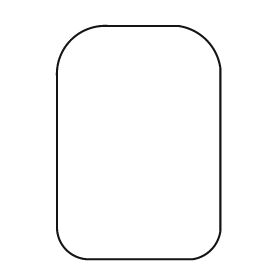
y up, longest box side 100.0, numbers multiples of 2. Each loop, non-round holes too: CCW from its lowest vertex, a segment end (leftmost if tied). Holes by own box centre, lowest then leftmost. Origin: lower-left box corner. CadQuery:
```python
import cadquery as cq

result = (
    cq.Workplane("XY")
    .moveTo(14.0, 0.0)
    .lineTo(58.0, 0.0)
    .threePointArc((66.0, 4.0), (70.0, 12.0))
    .lineTo(70.0, 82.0)
    .threePointArc((64.0, 94.0), (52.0, 100.0))
    .lineTo(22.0, 100.0)
    .threePointArc((6.0, 94.0), (0.0, 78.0))
    .lineTo(0.0, 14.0)
    .threePointArc((4.0, 4.0), (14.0, 0.0))
    .close()
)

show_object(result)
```